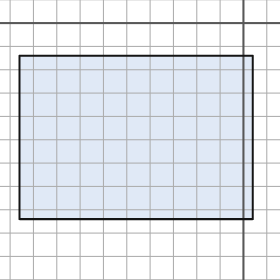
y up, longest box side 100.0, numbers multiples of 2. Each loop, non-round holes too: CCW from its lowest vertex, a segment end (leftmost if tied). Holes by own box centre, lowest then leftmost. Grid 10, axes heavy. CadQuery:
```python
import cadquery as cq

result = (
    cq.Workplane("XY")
    .moveTo(-96.0, -84.0)
    .lineTo(4.0, -84.0)
    .lineTo(4.0, -14.0)
    .lineTo(-96.0, -14.0)
    .close()
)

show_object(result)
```